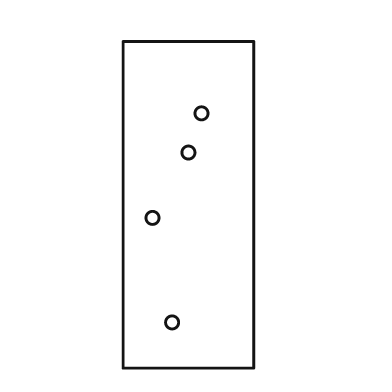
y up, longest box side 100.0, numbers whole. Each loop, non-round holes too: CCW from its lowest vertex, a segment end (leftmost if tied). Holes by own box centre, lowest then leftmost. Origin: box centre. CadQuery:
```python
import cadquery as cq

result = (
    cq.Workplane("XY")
    .moveTo(-20.0, -50.0)
    .lineTo(20.0, -50.0)
    .lineTo(20.0, 50.0)
    .lineTo(-20.0, 50.0)
    .close()
    .moveTo(-5.0, -36.0)
    .circle(2.0)
    .moveTo(-11.0, -4.0)
    .circle(2.0)
    .moveTo(0.0, 16.0)
    .circle(2.0)
    .moveTo(4.0, 28.0)
    .circle(2.0)
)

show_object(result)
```